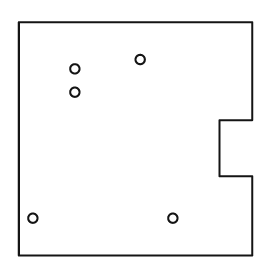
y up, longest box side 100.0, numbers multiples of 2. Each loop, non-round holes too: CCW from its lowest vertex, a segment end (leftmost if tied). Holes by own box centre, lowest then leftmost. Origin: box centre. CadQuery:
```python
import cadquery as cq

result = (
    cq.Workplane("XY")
    .moveTo(-50.0, -50.0)
    .lineTo(50.0, -50.0)
    .lineTo(50.0, -16.0)
    .lineTo(36.0, -16.0)
    .lineTo(36.0, 8.0)
    .lineTo(50.0, 8.0)
    .lineTo(50.0, 50.0)
    .lineTo(-50.0, 50.0)
    .close()
    .moveTo(-44.0, -34.0)
    .circle(2.0)
    .moveTo(16.0, -34.0)
    .circle(2.0)
    .moveTo(-26.0, 20.0)
    .circle(2.0)
    .moveTo(-26.0, 30.0)
    .circle(2.0)
    .moveTo(2.0, 34.0)
    .circle(2.0)
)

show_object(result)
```